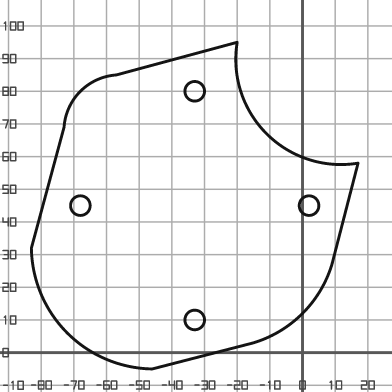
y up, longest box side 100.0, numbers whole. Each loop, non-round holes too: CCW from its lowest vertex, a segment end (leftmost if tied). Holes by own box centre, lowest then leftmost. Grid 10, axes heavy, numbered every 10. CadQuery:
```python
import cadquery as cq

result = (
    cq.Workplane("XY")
    .moveTo(-46.0, -5.0)
    .lineTo(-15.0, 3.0)
    .threePointArc((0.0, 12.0), (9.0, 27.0))
    .lineTo(17.0, 58.0)
    .threePointArc((-11.0, 67.0), (-20.0, 95.0))
    .lineTo(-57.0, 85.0)
    .threePointArc((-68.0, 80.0), (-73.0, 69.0))
    .lineTo(-83.0, 32.0)
    .threePointArc((-72.0, 6.0), (-46.0, -5.0))
    .close()
    .moveTo(-33.0, 10.0)
    .circle(3.0)
    .moveTo(-68.0, 45.0)
    .circle(3.0)
    .moveTo(2.0, 45.0)
    .circle(3.0)
    .moveTo(-33.0, 80.0)
    .circle(3.0)
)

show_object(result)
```